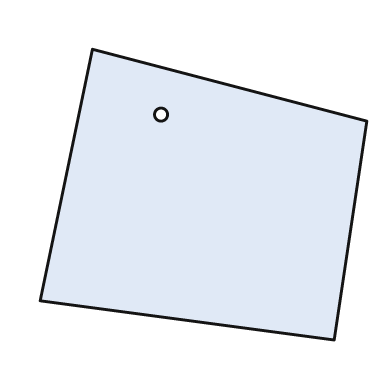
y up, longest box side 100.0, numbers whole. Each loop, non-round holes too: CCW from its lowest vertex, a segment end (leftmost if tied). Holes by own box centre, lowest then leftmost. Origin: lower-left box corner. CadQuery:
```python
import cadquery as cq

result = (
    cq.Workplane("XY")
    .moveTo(90.0, 0.0)
    .lineTo(100.0, 67.0)
    .lineTo(16.0, 89.0)
    .lineTo(0.0, 12.0)
    .close()
    .moveTo(37.0, 69.0)
    .circle(2.0)
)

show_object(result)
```